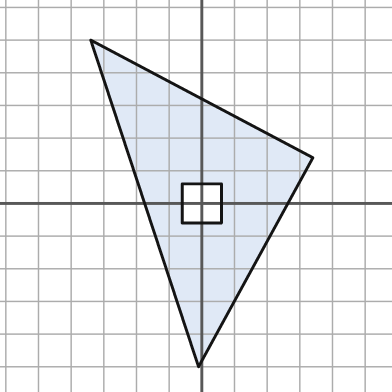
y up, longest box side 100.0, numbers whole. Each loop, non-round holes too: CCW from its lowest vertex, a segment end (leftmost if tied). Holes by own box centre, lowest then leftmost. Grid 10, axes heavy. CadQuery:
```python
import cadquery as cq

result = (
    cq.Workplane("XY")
    .moveTo(-1.0, -50.0)
    .lineTo(34.0, 14.0)
    .lineTo(-34.0, 50.0)
    .close()
    .moveTo(-6.0, -6.0)
    .lineTo(6.0, -6.0)
    .lineTo(6.0, 6.0)
    .lineTo(-6.0, 6.0)
    .close()
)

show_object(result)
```